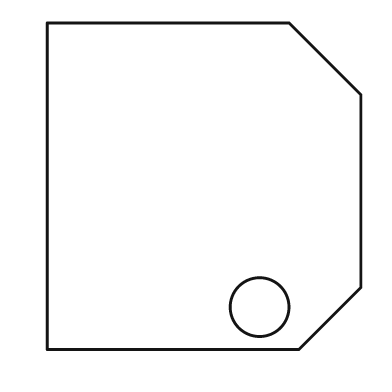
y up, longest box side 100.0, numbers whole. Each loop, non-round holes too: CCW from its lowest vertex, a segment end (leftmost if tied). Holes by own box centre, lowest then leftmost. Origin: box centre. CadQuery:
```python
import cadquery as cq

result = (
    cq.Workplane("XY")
    .moveTo(-48.0, -50.0)
    .lineTo(29.0, -50.0)
    .lineTo(48.0, -31.0)
    .lineTo(48.0, 28.0)
    .lineTo(26.0, 50.0)
    .lineTo(-48.0, 50.0)
    .close()
    .moveTo(17.0, -37.0)
    .circle(9.0)
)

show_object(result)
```